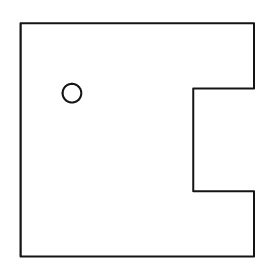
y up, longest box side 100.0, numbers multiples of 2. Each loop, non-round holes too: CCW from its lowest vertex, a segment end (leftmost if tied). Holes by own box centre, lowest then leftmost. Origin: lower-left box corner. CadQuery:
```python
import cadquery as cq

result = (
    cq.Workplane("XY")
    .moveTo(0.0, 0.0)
    .lineTo(100.0, 0.0)
    .lineTo(100.0, 28.0)
    .lineTo(74.0, 28.0)
    .lineTo(74.0, 72.0)
    .lineTo(100.0, 72.0)
    .lineTo(100.0, 100.0)
    .lineTo(0.0, 100.0)
    .close()
    .moveTo(22.0, 70.0)
    .circle(4.0)
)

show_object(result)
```